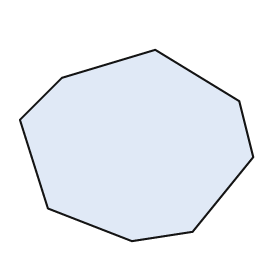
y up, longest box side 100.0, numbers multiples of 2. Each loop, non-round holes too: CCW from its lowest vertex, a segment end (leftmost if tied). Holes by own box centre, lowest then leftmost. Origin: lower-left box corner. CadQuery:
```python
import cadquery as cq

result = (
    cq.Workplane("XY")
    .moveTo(48.0, 0.0)
    .lineTo(74.0, 4.0)
    .lineTo(100.0, 36.0)
    .lineTo(94.0, 60.0)
    .lineTo(58.0, 82.0)
    .lineTo(18.0, 70.0)
    .lineTo(0.0, 52.0)
    .lineTo(12.0, 14.0)
    .close()
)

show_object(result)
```